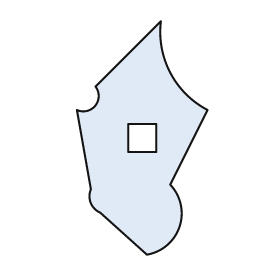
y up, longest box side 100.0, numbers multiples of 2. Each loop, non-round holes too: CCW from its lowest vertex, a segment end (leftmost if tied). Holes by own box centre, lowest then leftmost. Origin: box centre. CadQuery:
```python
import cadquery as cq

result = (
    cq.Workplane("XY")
    .moveTo(2.0, -50.0)
    .threePointArc((16.0, -38.0), (12.0, -20.0))
    .lineTo(28.0, 12.0)
    .threePointArc((12.0, 28.0), (8.0, 50.0))
    .lineTo(-20.0, 22.0)
    .threePointArc((-20.0, 14.0), (-28.0, 12.0))
    .lineTo(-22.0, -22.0)
    .threePointArc((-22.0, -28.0), (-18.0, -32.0))
    .close()
    .moveTo(-6.0, -6.0)
    .lineTo(6.0, -6.0)
    .lineTo(6.0, 6.0)
    .lineTo(-6.0, 6.0)
    .close()
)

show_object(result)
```